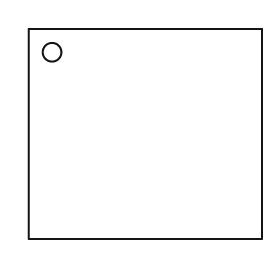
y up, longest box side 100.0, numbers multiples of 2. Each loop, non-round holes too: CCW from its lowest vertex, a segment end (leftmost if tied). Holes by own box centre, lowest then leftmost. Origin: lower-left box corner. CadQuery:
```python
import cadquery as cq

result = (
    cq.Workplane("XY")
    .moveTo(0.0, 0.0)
    .lineTo(100.0, 0.0)
    .lineTo(100.0, 90.0)
    .lineTo(0.0, 90.0)
    .close()
    .moveTo(10.0, 80.0)
    .circle(4.0)
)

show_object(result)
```